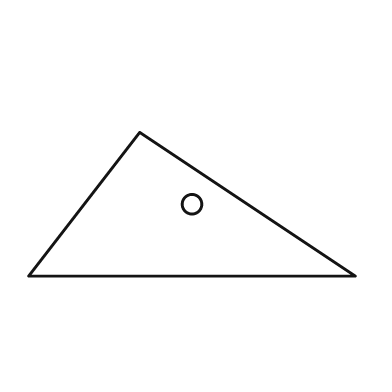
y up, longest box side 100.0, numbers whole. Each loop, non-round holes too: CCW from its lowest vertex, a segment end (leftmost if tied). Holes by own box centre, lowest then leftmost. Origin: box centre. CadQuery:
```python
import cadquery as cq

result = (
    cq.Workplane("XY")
    .moveTo(-50.0, -22.0)
    .lineTo(50.0, -22.0)
    .lineTo(-16.0, 22.0)
    .close()
    .moveTo(0.0, 0.0)
    .circle(3.0)
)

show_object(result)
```